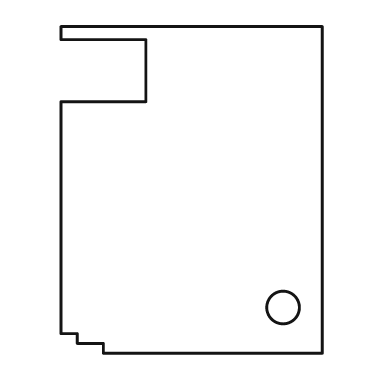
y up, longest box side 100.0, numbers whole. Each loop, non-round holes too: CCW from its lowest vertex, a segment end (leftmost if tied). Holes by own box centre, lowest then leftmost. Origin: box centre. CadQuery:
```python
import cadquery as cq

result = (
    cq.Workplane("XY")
    .moveTo(-27.0, -50.0)
    .lineTo(40.0, -50.0)
    .lineTo(40.0, 50.0)
    .lineTo(-40.0, 50.0)
    .lineTo(-40.0, 46.0)
    .lineTo(-14.0, 46.0)
    .lineTo(-14.0, 27.0)
    .lineTo(-40.0, 27.0)
    .lineTo(-40.0, -44.0)
    .lineTo(-35.0, -44.0)
    .lineTo(-35.0, -47.0)
    .lineTo(-27.0, -47.0)
    .close()
    .moveTo(28.0, -36.0)
    .circle(5.0)
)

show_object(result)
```